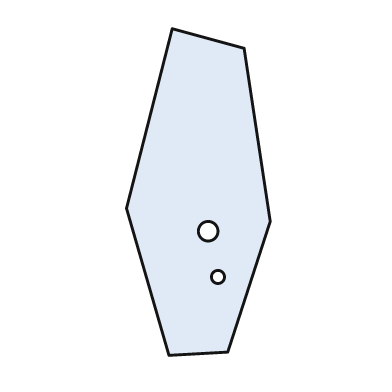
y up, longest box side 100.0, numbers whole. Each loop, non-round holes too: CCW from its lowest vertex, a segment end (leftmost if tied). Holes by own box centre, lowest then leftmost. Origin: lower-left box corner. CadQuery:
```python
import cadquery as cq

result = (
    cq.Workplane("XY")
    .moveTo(13.0, 0.0)
    .lineTo(31.0, 1.0)
    .lineTo(44.0, 41.0)
    .lineTo(36.0, 94.0)
    .lineTo(14.0, 100.0)
    .lineTo(0.0, 45.0)
    .close()
    .moveTo(28.0, 24.0)
    .circle(2.0)
    .moveTo(25.0, 38.0)
    .circle(3.0)
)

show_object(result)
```